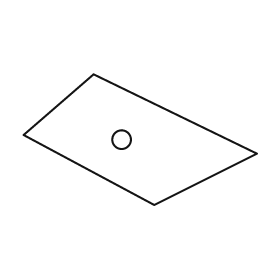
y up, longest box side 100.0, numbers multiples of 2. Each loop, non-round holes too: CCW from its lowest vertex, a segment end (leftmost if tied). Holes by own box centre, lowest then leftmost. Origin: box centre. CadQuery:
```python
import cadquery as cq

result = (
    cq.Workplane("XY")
    .moveTo(6.0, -28.0)
    .lineTo(50.0, -6.0)
    .lineTo(-20.0, 28.0)
    .lineTo(-50.0, 2.0)
    .close()
    .moveTo(-8.0, 0.0)
    .circle(4.0)
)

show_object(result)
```